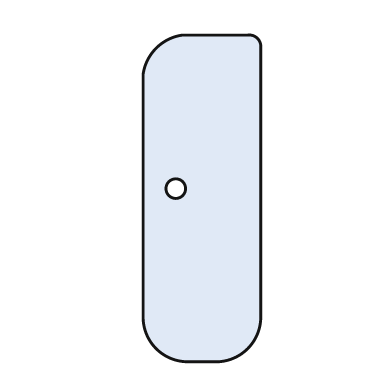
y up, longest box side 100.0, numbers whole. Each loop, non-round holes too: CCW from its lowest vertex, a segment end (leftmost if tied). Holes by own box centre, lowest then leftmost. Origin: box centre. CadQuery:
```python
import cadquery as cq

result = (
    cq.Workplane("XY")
    .moveTo(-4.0, -50.0)
    .lineTo(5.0, -50.0)
    .threePointArc((14.0, -46.0), (18.0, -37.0))
    .lineTo(18.0, 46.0)
    .threePointArc((17.0, 49.0), (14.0, 50.0))
    .lineTo(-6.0, 50.0)
    .threePointArc((-14.0, 46.0), (-18.0, 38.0))
    .lineTo(-18.0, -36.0)
    .threePointArc((-14.0, -46.0), (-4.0, -50.0))
    .close()
    .moveTo(-8.0, 3.0)
    .circle(3.0)
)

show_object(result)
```